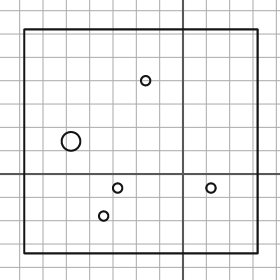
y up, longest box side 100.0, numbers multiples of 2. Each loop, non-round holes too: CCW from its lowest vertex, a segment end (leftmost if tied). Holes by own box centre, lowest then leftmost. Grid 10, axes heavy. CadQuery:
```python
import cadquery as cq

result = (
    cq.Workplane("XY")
    .moveTo(-68.0, -34.0)
    .lineTo(32.0, -34.0)
    .lineTo(32.0, 62.0)
    .lineTo(-68.0, 62.0)
    .close()
    .moveTo(-34.0, -18.0)
    .circle(2.0)
    .moveTo(-28.0, -6.0)
    .circle(2.0)
    .moveTo(12.0, -6.0)
    .circle(2.0)
    .moveTo(-48.0, 14.0)
    .circle(4.0)
    .moveTo(-16.0, 40.0)
    .circle(2.0)
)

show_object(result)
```